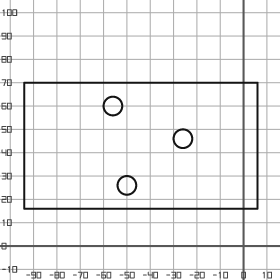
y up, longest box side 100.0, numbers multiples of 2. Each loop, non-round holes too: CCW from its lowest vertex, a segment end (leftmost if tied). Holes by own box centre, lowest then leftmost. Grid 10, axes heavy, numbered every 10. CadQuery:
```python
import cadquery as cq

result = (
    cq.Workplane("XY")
    .moveTo(-94.0, 16.0)
    .lineTo(6.0, 16.0)
    .lineTo(6.0, 70.0)
    .lineTo(-94.0, 70.0)
    .close()
    .moveTo(-50.0, 26.0)
    .circle(4.0)
    .moveTo(-26.0, 46.0)
    .circle(4.0)
    .moveTo(-56.0, 60.0)
    .circle(4.0)
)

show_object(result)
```